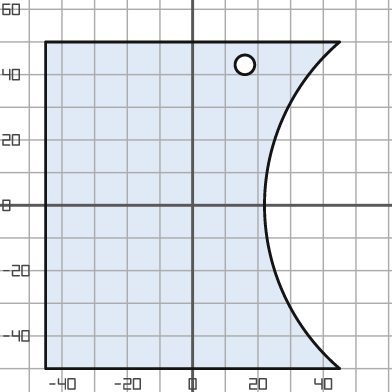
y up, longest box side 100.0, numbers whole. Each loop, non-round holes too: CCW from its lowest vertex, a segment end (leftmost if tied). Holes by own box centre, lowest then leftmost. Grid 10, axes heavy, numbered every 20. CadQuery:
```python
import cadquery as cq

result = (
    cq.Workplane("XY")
    .moveTo(-45.0, -50.0)
    .lineTo(45.0, -50.0)
    .threePointArc((22.0, 0.0), (45.0, 50.0))
    .lineTo(-45.0, 50.0)
    .close()
    .moveTo(16.0, 43.0)
    .circle(3.0)
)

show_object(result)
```